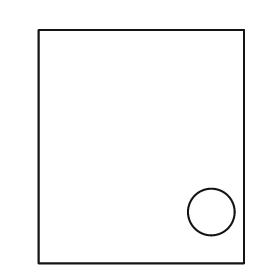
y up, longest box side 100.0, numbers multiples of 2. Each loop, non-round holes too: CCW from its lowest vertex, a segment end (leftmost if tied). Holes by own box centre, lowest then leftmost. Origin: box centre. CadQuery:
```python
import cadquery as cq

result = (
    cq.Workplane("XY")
    .moveTo(-44.0, -50.0)
    .lineTo(44.0, -50.0)
    .lineTo(44.0, 50.0)
    .lineTo(-44.0, 50.0)
    .close()
    .moveTo(30.0, -28.0)
    .circle(10.0)
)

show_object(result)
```